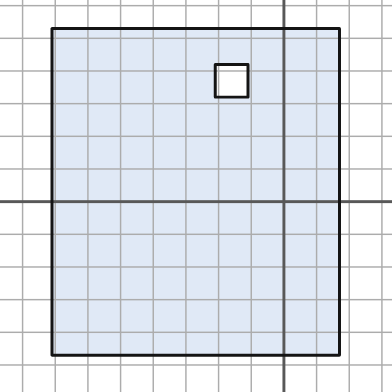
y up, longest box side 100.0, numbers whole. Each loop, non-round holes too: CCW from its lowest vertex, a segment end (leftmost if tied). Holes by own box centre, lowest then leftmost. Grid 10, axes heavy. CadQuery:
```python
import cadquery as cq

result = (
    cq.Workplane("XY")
    .moveTo(-71.0, -47.0)
    .lineTo(17.0, -47.0)
    .lineTo(17.0, 53.0)
    .lineTo(-71.0, 53.0)
    .close()
    .moveTo(-21.0, 32.0)
    .lineTo(-11.0, 32.0)
    .lineTo(-11.0, 42.0)
    .lineTo(-21.0, 42.0)
    .close()
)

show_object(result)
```